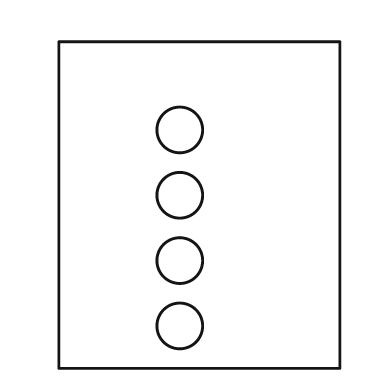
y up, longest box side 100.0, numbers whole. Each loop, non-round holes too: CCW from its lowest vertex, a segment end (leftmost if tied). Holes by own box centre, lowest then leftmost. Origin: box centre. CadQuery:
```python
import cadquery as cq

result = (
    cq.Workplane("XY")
    .moveTo(-43.0, -50.0)
    .lineTo(43.0, -50.0)
    .lineTo(43.0, 50.0)
    .lineTo(-43.0, 50.0)
    .close()
    .moveTo(-6.0, -37.0)
    .circle(7.0)
    .moveTo(-6.0, -17.0)
    .circle(7.0)
    .moveTo(-6.0, 3.0)
    .circle(7.0)
    .moveTo(-6.0, 23.0)
    .circle(7.0)
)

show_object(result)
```